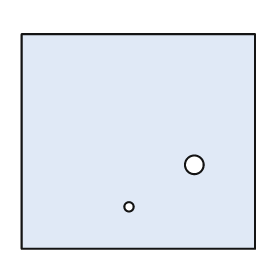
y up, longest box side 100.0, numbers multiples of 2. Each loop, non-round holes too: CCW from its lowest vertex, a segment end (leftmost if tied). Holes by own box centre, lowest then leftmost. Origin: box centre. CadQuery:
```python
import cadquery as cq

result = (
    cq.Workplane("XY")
    .moveTo(-50.0, -46.0)
    .lineTo(50.0, -46.0)
    .lineTo(50.0, 46.0)
    .lineTo(-50.0, 46.0)
    .close()
    .moveTo(-4.0, -28.0)
    .circle(2.0)
    .moveTo(24.0, -10.0)
    .circle(4.0)
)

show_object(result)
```